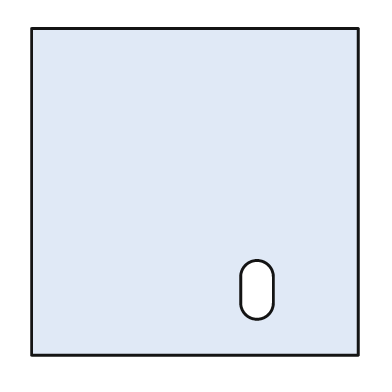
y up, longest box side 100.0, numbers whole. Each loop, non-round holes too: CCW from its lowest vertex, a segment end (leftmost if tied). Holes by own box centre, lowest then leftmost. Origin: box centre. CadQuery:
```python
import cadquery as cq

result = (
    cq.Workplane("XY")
    .moveTo(-50.0, -50.0)
    .lineTo(50.0, -50.0)
    .lineTo(50.0, 50.0)
    .lineTo(-50.0, 50.0)
    .close()
    .moveTo(14.0, -34.0)
    .threePointArc((19.0, -39.0), (24.0, -34.0))
    .lineTo(24.0, -26.0)
    .threePointArc((19.0, -21.0), (14.0, -26.0))
    .close()
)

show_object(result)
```